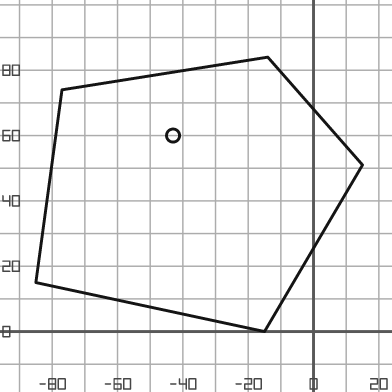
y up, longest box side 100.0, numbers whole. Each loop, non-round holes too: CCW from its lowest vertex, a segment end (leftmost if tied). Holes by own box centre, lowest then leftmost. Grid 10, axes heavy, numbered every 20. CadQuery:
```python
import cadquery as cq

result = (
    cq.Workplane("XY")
    .moveTo(-15.0, 0.0)
    .lineTo(15.0, 51.0)
    .lineTo(-14.0, 84.0)
    .lineTo(-77.0, 74.0)
    .lineTo(-85.0, 15.0)
    .close()
    .moveTo(-43.0, 60.0)
    .circle(2.0)
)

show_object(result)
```